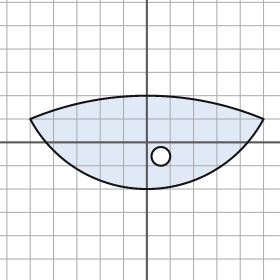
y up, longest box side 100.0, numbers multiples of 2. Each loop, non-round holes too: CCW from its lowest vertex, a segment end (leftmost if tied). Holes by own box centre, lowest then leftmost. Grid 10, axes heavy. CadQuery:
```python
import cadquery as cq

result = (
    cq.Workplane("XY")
    .moveTo(-50.0, 10.0)
    .threePointArc((0.0, -20.0), (50.0, 10.0))
    .threePointArc((0.0, 20.0), (-50.0, 10.0))
    .close()
    .moveTo(6.0, -6.0)
    .circle(4.0)
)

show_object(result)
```